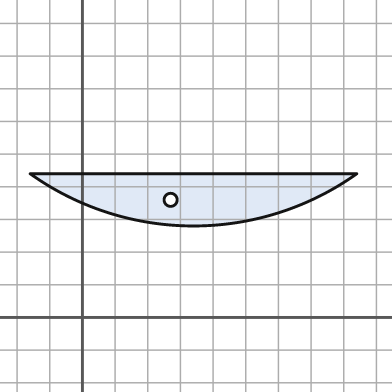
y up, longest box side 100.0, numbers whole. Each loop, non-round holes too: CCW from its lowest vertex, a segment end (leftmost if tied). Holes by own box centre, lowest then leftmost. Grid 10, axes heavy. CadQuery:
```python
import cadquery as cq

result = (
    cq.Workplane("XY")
    .moveTo(-16.0, 44.0)
    .threePointArc((34.0, 28.0), (84.0, 44.0))
    .close()
    .moveTo(27.0, 36.0)
    .circle(2.0)
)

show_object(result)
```